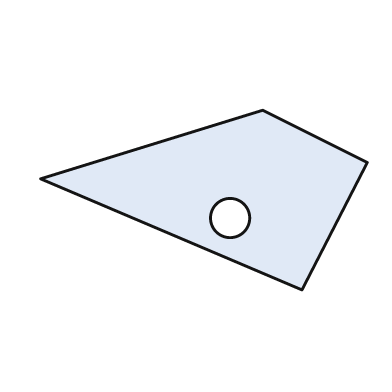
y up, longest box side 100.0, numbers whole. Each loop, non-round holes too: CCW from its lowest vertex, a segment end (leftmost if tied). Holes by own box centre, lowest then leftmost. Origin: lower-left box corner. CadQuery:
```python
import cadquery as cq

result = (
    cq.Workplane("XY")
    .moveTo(80.0, 0.0)
    .lineTo(100.0, 39.0)
    .lineTo(68.0, 55.0)
    .lineTo(0.0, 34.0)
    .close()
    .moveTo(58.0, 22.0)
    .circle(6.0)
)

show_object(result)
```